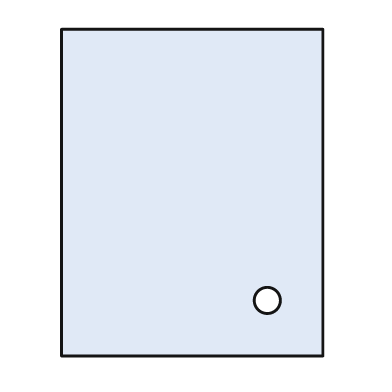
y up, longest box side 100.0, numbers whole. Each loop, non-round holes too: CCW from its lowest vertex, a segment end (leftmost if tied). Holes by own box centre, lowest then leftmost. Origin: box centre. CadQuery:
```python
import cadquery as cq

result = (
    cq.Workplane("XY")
    .moveTo(-40.0, -50.0)
    .lineTo(40.0, -50.0)
    .lineTo(40.0, 50.0)
    .lineTo(-40.0, 50.0)
    .close()
    .moveTo(23.0, -33.0)
    .circle(4.0)
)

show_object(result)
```